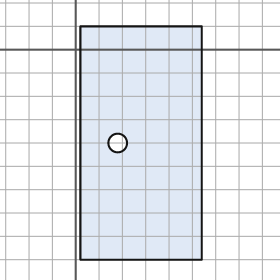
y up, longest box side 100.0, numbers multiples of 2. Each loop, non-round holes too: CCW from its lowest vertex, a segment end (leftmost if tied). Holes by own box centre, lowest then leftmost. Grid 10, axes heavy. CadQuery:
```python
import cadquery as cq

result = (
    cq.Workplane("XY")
    .moveTo(2.0, -90.0)
    .lineTo(54.0, -90.0)
    .lineTo(54.0, 10.0)
    .lineTo(2.0, 10.0)
    .close()
    .moveTo(18.0, -40.0)
    .circle(4.0)
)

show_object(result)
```